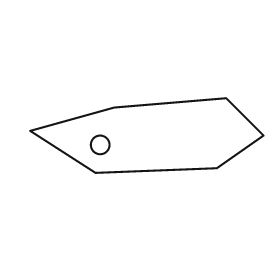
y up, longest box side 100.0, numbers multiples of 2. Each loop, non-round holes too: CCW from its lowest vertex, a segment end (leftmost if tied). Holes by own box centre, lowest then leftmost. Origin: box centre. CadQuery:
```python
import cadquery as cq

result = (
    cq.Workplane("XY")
    .moveTo(-22.0, -16.0)
    .lineTo(30.0, -14.0)
    .lineTo(50.0, 0.0)
    .lineTo(34.0, 16.0)
    .lineTo(-14.0, 12.0)
    .lineTo(-50.0, 2.0)
    .close()
    .moveTo(-20.0, -4.0)
    .circle(4.0)
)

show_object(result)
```